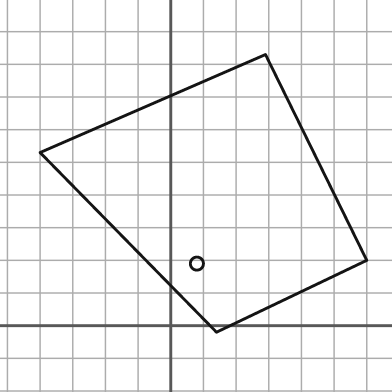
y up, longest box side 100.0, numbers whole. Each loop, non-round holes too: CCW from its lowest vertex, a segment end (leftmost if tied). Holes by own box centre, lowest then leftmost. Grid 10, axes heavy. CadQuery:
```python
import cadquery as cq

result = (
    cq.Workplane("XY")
    .moveTo(14.0, -2.0)
    .lineTo(60.0, 20.0)
    .lineTo(29.0, 83.0)
    .lineTo(-40.0, 53.0)
    .close()
    .moveTo(8.0, 19.0)
    .circle(2.0)
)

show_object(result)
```